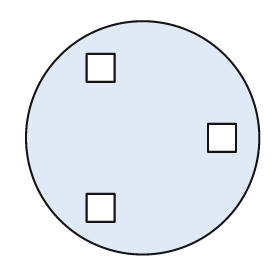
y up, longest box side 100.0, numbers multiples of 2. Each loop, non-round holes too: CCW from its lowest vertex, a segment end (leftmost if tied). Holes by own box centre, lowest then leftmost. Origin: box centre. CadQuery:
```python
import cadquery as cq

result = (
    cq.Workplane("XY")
    .moveTo(0.0, 0.0)
    .circle(50.0)
    .moveTo(-24.0, -36.0)
    .lineTo(-12.0, -36.0)
    .lineTo(-12.0, -24.0)
    .lineTo(-24.0, -24.0)
    .close()
    .moveTo(28.0, -6.0)
    .lineTo(40.0, -6.0)
    .lineTo(40.0, 6.0)
    .lineTo(28.0, 6.0)
    .close()
    .moveTo(-24.0, 24.0)
    .lineTo(-12.0, 24.0)
    .lineTo(-12.0, 36.0)
    .lineTo(-24.0, 36.0)
    .close()
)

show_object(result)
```